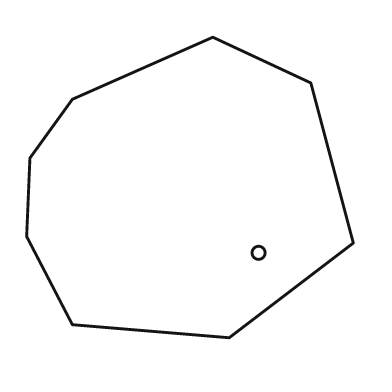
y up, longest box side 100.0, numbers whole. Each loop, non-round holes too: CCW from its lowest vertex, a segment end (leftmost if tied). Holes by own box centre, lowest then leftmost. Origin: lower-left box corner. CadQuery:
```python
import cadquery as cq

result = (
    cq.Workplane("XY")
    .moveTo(62.0, 0.0)
    .lineTo(100.0, 29.0)
    .lineTo(87.0, 78.0)
    .lineTo(57.0, 92.0)
    .lineTo(14.0, 73.0)
    .lineTo(1.0, 55.0)
    .lineTo(0.0, 31.0)
    .lineTo(14.0, 4.0)
    .close()
    .moveTo(71.0, 26.0)
    .circle(2.0)
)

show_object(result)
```